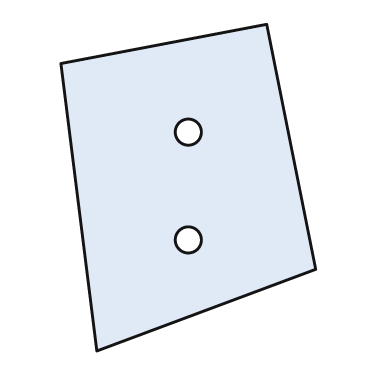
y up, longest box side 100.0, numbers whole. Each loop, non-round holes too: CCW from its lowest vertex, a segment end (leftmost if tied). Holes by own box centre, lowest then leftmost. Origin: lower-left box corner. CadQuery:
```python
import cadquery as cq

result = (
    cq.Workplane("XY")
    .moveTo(11.0, 0.0)
    .lineTo(78.0, 25.0)
    .lineTo(63.0, 100.0)
    .lineTo(0.0, 88.0)
    .close()
    .moveTo(39.0, 34.0)
    .circle(4.0)
    .moveTo(39.0, 67.0)
    .circle(4.0)
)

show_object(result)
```